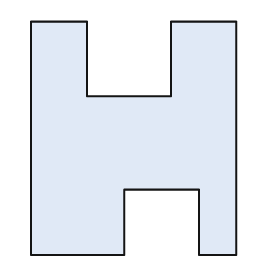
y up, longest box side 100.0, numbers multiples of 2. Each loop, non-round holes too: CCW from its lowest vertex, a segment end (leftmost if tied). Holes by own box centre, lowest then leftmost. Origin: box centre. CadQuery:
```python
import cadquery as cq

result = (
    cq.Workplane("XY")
    .moveTo(-44.0, -50.0)
    .lineTo(-4.0, -50.0)
    .lineTo(-4.0, -22.0)
    .lineTo(28.0, -22.0)
    .lineTo(28.0, -50.0)
    .lineTo(44.0, -50.0)
    .lineTo(44.0, 50.0)
    .lineTo(16.0, 50.0)
    .lineTo(16.0, 18.0)
    .lineTo(-20.0, 18.0)
    .lineTo(-20.0, 50.0)
    .lineTo(-44.0, 50.0)
    .close()
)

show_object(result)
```